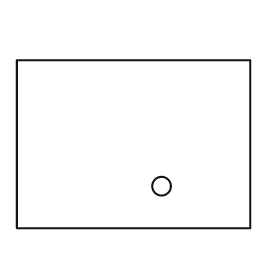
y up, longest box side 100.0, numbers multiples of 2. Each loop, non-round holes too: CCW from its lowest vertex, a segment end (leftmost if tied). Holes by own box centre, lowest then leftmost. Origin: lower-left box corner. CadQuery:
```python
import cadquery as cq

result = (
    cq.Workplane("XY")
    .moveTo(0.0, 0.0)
    .lineTo(100.0, 0.0)
    .lineTo(100.0, 72.0)
    .lineTo(0.0, 72.0)
    .close()
    .moveTo(62.0, 18.0)
    .circle(4.0)
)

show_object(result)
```